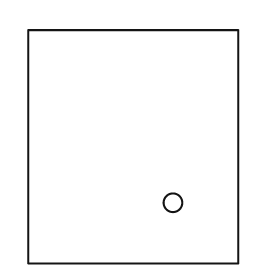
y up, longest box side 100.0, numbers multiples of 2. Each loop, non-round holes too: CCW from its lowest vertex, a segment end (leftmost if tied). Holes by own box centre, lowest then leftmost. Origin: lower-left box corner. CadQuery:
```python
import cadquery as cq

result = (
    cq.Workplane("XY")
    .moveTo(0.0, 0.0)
    .lineTo(90.0, 0.0)
    .lineTo(90.0, 100.0)
    .lineTo(0.0, 100.0)
    .close()
    .moveTo(62.0, 26.0)
    .circle(4.0)
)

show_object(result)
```